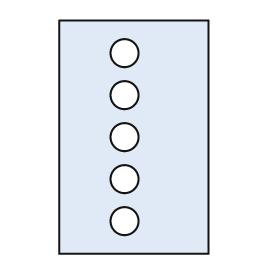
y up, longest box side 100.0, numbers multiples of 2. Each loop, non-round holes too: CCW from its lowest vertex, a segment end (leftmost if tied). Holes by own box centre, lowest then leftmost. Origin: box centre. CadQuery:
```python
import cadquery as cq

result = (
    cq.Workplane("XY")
    .moveTo(-32.0, -50.0)
    .lineTo(32.0, -50.0)
    .lineTo(32.0, 50.0)
    .lineTo(-32.0, 50.0)
    .close()
    .moveTo(-4.0, -36.0)
    .circle(6.0)
    .moveTo(-4.0, -18.0)
    .circle(6.0)
    .moveTo(-4.0, 0.0)
    .circle(6.0)
    .moveTo(-4.0, 18.0)
    .circle(6.0)
    .moveTo(-4.0, 36.0)
    .circle(6.0)
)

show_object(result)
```